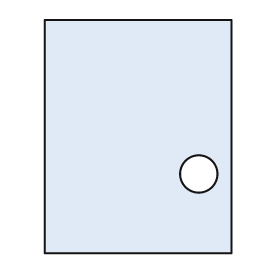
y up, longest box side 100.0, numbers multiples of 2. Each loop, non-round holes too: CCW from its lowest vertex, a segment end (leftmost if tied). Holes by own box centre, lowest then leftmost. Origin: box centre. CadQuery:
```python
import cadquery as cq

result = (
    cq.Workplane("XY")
    .moveTo(-40.0, -50.0)
    .lineTo(40.0, -50.0)
    .lineTo(40.0, 50.0)
    .lineTo(-40.0, 50.0)
    .close()
    .moveTo(26.0, -16.0)
    .circle(8.0)
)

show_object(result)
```